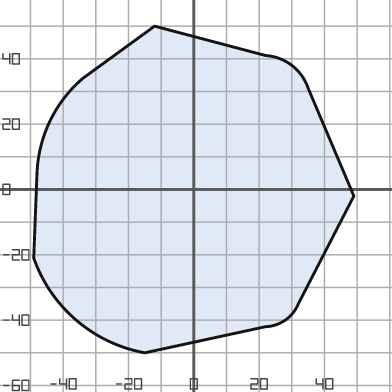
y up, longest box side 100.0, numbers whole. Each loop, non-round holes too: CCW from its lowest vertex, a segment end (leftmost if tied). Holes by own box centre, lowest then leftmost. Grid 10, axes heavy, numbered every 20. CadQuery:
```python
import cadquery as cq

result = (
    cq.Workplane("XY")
    .moveTo(-15.0, -50.0)
    .lineTo(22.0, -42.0)
    .threePointArc((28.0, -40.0), (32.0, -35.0))
    .lineTo(49.0, -2.0)
    .lineTo(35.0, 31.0)
    .threePointArc((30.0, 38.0), (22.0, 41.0))
    .lineTo(-12.0, 50.0)
    .lineTo(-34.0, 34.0)
    .threePointArc((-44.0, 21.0), (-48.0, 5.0))
    .lineTo(-49.0, -21.0)
    .threePointArc((-36.0, -40.0), (-15.0, -50.0))
    .close()
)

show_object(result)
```